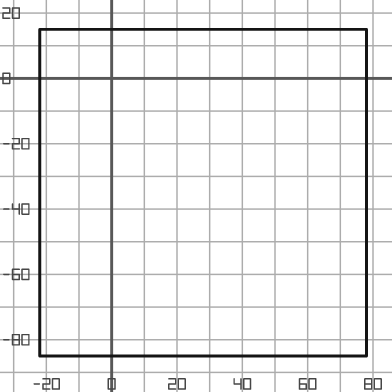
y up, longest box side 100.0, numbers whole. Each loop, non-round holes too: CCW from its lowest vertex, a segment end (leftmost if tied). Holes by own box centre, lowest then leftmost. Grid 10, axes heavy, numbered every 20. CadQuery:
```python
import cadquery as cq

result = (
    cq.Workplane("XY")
    .moveTo(-22.0, -85.0)
    .lineTo(78.0, -85.0)
    .lineTo(78.0, 15.0)
    .lineTo(-22.0, 15.0)
    .close()
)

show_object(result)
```